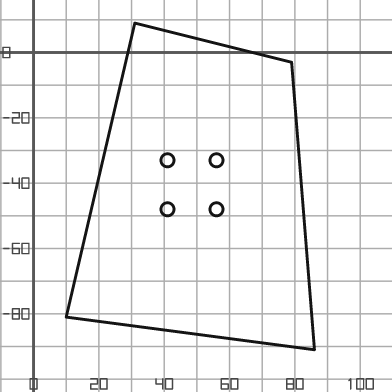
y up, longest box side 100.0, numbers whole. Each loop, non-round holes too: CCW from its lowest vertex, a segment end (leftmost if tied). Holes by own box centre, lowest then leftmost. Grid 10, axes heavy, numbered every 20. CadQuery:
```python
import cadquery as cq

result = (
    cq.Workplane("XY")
    .moveTo(86.0, -91.0)
    .lineTo(79.0, -3.0)
    .lineTo(31.0, 9.0)
    .lineTo(10.0, -81.0)
    .close()
    .moveTo(41.0, -48.0)
    .circle(2.0)
    .moveTo(56.0, -48.0)
    .circle(2.0)
    .moveTo(41.0, -33.0)
    .circle(2.0)
    .moveTo(56.0, -33.0)
    .circle(2.0)
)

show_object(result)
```